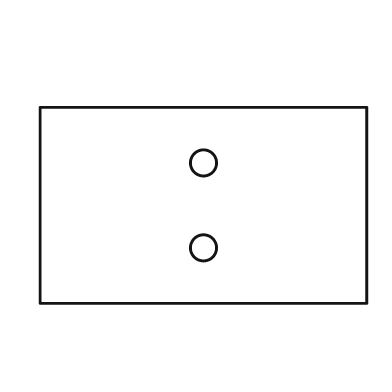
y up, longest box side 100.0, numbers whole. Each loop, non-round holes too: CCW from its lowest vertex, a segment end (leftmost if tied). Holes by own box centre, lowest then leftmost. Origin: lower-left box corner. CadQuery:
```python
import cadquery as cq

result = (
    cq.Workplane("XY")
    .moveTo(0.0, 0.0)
    .lineTo(100.0, 0.0)
    .lineTo(100.0, 60.0)
    .lineTo(0.0, 60.0)
    .close()
    .moveTo(50.0, 17.0)
    .circle(4.0)
    .moveTo(50.0, 43.0)
    .circle(4.0)
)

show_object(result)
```